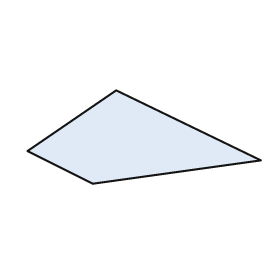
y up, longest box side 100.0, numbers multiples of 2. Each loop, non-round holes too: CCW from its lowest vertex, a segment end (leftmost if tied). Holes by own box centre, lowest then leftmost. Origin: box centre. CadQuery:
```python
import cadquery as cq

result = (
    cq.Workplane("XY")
    .moveTo(-22.0, -20.0)
    .lineTo(50.0, -10.0)
    .lineTo(-12.0, 20.0)
    .lineTo(-50.0, -6.0)
    .close()
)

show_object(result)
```